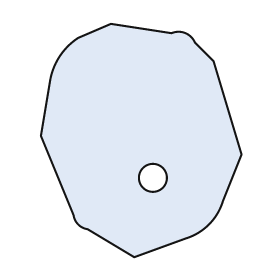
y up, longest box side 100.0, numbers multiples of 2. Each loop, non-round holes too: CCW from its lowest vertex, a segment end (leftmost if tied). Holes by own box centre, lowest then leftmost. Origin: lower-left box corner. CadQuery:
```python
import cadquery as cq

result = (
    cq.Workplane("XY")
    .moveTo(40.0, 0.0)
    .lineTo(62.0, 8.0)
    .threePointArc((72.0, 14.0), (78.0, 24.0))
    .lineTo(86.0, 44.0)
    .lineTo(74.0, 84.0)
    .lineTo(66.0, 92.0)
    .threePointArc((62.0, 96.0), (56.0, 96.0))
    .lineTo(30.0, 100.0)
    .lineTo(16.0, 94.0)
    .threePointArc((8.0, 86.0), (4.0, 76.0))
    .lineTo(0.0, 52.0)
    .lineTo(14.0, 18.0)
    .threePointArc((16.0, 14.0), (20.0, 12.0))
    .close()
    .moveTo(48.0, 34.0)
    .circle(6.0)
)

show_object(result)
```